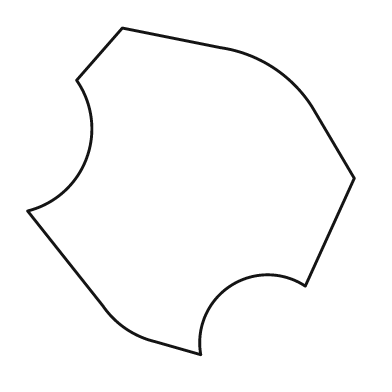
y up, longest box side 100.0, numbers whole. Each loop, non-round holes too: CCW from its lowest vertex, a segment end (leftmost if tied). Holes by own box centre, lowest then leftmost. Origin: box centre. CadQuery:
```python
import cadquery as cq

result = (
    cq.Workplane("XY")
    .moveTo(3.0, -50.0)
    .threePointArc((12.0, -29.0), (35.0, -29.0))
    .lineTo(50.0, 4.0)
    .lineTo(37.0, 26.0)
    .threePointArc((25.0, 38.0), (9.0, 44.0))
    .lineTo(-21.0, 50.0)
    .lineTo(-35.0, 34.0)
    .threePointArc((-32.0, 10.0), (-50.0, -6.0))
    .lineTo(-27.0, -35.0)
    .threePointArc((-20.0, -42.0), (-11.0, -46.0))
    .close()
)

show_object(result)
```